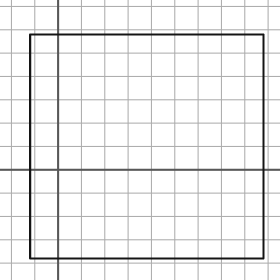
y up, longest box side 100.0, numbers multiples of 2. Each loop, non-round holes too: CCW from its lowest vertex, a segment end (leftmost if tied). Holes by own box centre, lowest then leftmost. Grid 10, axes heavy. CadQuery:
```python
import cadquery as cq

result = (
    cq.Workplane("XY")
    .moveTo(-12.0, -38.0)
    .lineTo(88.0, -38.0)
    .lineTo(88.0, 58.0)
    .lineTo(-12.0, 58.0)
    .close()
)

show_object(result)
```